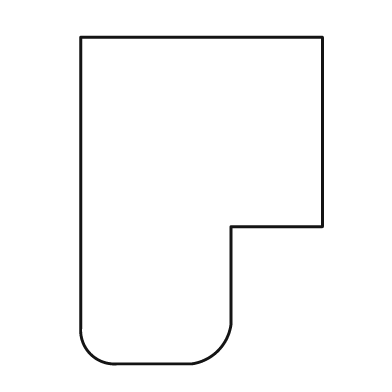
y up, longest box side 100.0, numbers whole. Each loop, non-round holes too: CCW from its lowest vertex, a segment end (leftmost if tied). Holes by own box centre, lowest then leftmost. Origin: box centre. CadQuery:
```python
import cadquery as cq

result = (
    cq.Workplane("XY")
    .moveTo(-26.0, -50.0)
    .lineTo(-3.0, -50.0)
    .threePointArc((5.0, -46.0), (9.0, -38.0))
    .lineTo(9.0, -8.0)
    .lineTo(37.0, -8.0)
    .lineTo(37.0, 50.0)
    .lineTo(-37.0, 50.0)
    .lineTo(-37.0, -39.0)
    .threePointArc((-34.0, -47.0), (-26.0, -50.0))
    .close()
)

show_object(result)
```